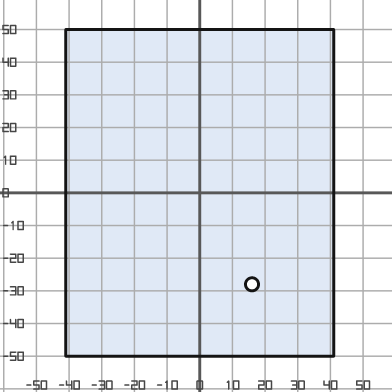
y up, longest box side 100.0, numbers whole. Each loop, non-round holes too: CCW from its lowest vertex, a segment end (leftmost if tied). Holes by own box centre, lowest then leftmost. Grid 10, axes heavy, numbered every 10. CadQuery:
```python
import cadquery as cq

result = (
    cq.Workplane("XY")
    .moveTo(-41.0, -50.0)
    .lineTo(41.0, -50.0)
    .lineTo(41.0, 50.0)
    .lineTo(-41.0, 50.0)
    .close()
    .moveTo(16.0, -28.0)
    .circle(2.0)
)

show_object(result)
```